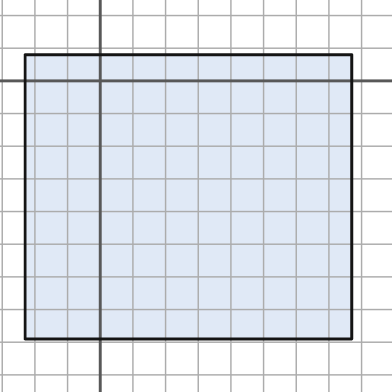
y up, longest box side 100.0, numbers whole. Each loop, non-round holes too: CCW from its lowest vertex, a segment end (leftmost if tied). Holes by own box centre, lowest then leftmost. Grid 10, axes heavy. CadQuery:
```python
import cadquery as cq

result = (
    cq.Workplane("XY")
    .moveTo(-23.0, -79.0)
    .lineTo(77.0, -79.0)
    .lineTo(77.0, 8.0)
    .lineTo(-23.0, 8.0)
    .close()
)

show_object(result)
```